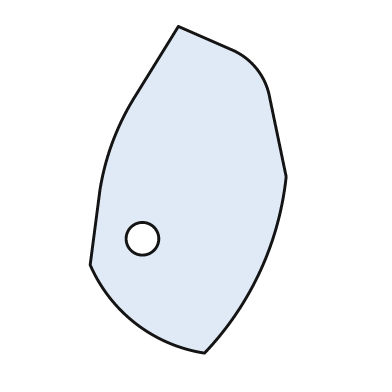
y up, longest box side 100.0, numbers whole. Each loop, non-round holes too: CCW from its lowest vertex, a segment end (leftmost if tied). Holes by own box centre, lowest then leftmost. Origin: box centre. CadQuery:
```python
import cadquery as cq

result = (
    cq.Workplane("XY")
    .moveTo(5.0, -50.0)
    .threePointArc((22.0, -25.0), (30.0, 4.0))
    .lineTo(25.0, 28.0)
    .threePointArc((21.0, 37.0), (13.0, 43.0))
    .lineTo(-3.0, 50.0)
    .lineTo(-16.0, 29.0)
    .threePointArc((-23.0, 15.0), (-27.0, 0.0))
    .lineTo(-30.0, -23.0)
    .threePointArc((-16.0, -41.0), (5.0, -50.0))
    .close()
    .moveTo(-14.0, -15.0)
    .circle(5.0)
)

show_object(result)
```